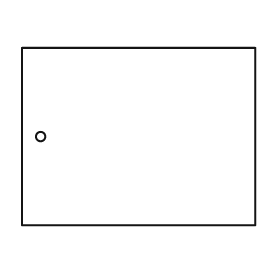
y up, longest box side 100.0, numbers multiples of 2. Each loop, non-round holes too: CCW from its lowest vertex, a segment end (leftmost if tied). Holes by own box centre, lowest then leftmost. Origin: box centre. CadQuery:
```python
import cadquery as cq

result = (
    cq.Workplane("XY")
    .moveTo(-50.0, -38.0)
    .lineTo(50.0, -38.0)
    .lineTo(50.0, 38.0)
    .lineTo(-50.0, 38.0)
    .close()
    .moveTo(-42.0, 0.0)
    .circle(2.0)
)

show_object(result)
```